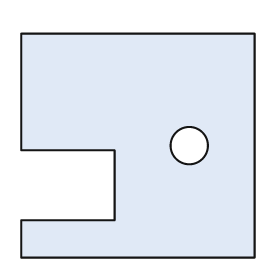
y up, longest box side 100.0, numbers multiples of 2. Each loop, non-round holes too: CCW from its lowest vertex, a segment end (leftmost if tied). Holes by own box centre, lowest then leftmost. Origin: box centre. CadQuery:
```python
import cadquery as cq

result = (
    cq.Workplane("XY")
    .moveTo(-50.0, -48.0)
    .lineTo(50.0, -48.0)
    .lineTo(50.0, 48.0)
    .lineTo(-50.0, 48.0)
    .lineTo(-50.0, -2.0)
    .lineTo(-10.0, -2.0)
    .lineTo(-10.0, -32.0)
    .lineTo(-50.0, -32.0)
    .close()
    .moveTo(22.0, 0.0)
    .circle(8.0)
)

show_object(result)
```